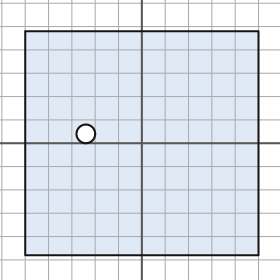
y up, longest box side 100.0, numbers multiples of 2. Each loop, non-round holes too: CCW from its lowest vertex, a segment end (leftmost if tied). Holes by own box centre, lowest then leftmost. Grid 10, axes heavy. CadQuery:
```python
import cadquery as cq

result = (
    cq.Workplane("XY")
    .moveTo(-50.0, -48.0)
    .lineTo(50.0, -48.0)
    .lineTo(50.0, 48.0)
    .lineTo(-50.0, 48.0)
    .close()
    .moveTo(-24.0, 4.0)
    .circle(4.0)
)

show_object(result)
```